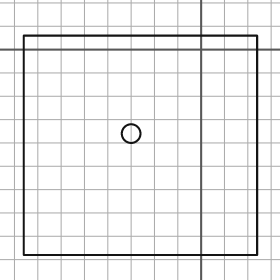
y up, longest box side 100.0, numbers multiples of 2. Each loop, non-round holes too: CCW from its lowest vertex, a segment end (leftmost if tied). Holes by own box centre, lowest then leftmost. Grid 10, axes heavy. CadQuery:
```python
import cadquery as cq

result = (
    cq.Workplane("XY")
    .moveTo(-76.0, -88.0)
    .lineTo(24.0, -88.0)
    .lineTo(24.0, 6.0)
    .lineTo(-76.0, 6.0)
    .close()
    .moveTo(-30.0, -36.0)
    .circle(4.0)
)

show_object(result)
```